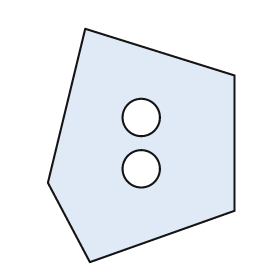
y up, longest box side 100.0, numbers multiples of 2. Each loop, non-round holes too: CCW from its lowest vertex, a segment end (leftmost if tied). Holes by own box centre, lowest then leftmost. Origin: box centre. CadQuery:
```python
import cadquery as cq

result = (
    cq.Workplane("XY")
    .moveTo(-22.0, -50.0)
    .lineTo(40.0, -28.0)
    .lineTo(40.0, 30.0)
    .lineTo(-24.0, 50.0)
    .lineTo(-40.0, -16.0)
    .close()
    .moveTo(0.0, -10.0)
    .circle(8.0)
    .moveTo(0.0, 12.0)
    .circle(8.0)
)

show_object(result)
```